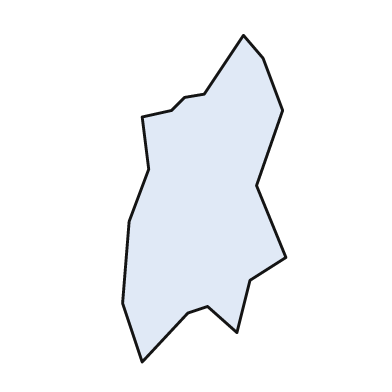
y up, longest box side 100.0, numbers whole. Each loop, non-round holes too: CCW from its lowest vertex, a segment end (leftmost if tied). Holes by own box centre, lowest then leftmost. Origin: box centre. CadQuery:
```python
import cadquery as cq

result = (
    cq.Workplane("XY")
    .moveTo(-19.0, -50.0)
    .lineTo(-5.0, -35.0)
    .lineTo(1.0, -33.0)
    .lineTo(10.0, -41.0)
    .lineTo(14.0, -25.0)
    .lineTo(25.0, -18.0)
    .lineTo(16.0, 4.0)
    .lineTo(24.0, 27.0)
    .lineTo(18.0, 43.0)
    .lineTo(12.0, 50.0)
    .lineTo(0.0, 32.0)
    .lineTo(-6.0, 31.0)
    .lineTo(-10.0, 27.0)
    .lineTo(-19.0, 25.0)
    .lineTo(-17.0, 9.0)
    .lineTo(-23.0, -7.0)
    .lineTo(-25.0, -32.0)
    .close()
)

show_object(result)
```